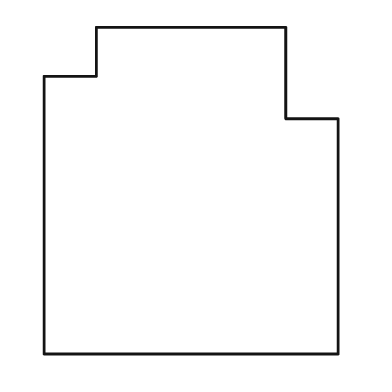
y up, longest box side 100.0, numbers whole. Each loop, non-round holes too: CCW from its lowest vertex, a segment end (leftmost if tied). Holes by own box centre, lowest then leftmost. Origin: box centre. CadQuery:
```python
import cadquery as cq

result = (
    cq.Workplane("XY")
    .moveTo(-45.0, -50.0)
    .lineTo(45.0, -50.0)
    .lineTo(45.0, 22.0)
    .lineTo(29.0, 22.0)
    .lineTo(29.0, 50.0)
    .lineTo(-29.0, 50.0)
    .lineTo(-29.0, 35.0)
    .lineTo(-45.0, 35.0)
    .close()
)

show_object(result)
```